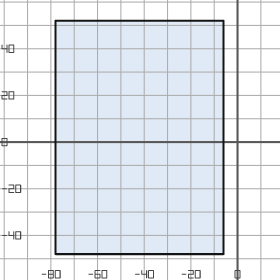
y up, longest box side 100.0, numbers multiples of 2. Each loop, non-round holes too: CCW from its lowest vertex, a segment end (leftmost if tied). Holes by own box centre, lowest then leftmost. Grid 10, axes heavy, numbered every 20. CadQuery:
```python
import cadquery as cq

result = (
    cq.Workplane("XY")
    .moveTo(-78.0, -48.0)
    .lineTo(-6.0, -48.0)
    .lineTo(-6.0, 52.0)
    .lineTo(-78.0, 52.0)
    .close()
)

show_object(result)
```